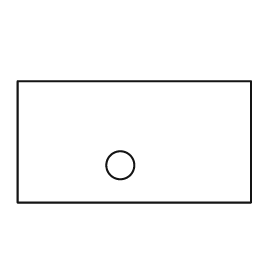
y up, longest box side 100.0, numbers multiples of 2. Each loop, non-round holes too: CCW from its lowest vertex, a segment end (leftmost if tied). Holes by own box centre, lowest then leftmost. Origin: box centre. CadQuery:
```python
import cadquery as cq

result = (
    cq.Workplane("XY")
    .moveTo(-50.0, -26.0)
    .lineTo(50.0, -26.0)
    .lineTo(50.0, 26.0)
    .lineTo(-50.0, 26.0)
    .close()
    .moveTo(-6.0, -10.0)
    .circle(6.0)
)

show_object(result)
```